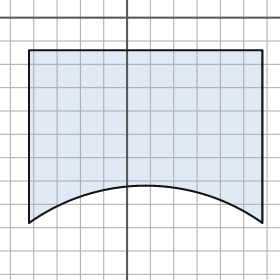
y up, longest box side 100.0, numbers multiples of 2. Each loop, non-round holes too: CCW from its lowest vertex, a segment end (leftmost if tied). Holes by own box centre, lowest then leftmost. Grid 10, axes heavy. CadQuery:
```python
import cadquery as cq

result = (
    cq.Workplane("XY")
    .moveTo(-42.0, -88.0)
    .threePointArc((8.0, -72.0), (58.0, -88.0))
    .lineTo(58.0, -14.0)
    .lineTo(-42.0, -14.0)
    .close()
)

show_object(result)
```